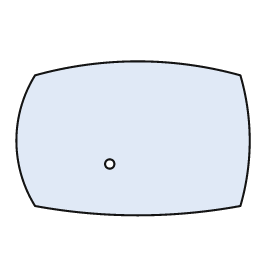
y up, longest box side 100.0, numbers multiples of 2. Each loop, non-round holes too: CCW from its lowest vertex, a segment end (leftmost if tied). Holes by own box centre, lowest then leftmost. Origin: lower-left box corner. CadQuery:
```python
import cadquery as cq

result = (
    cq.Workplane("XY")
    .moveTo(8.0, 4.0)
    .threePointArc((52.0, 0.0), (96.0, 4.0))
    .threePointArc((100.0, 32.0), (96.0, 60.0))
    .threePointArc((52.0, 66.0), (8.0, 60.0))
    .threePointArc((0.0, 32.0), (8.0, 4.0))
    .close()
    .moveTo(40.0, 22.0)
    .circle(2.0)
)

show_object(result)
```